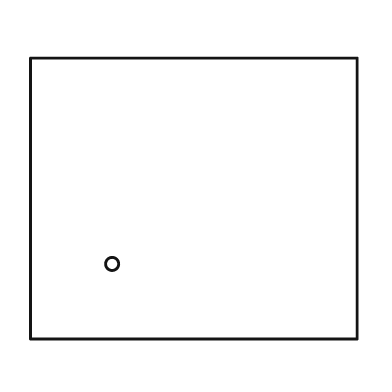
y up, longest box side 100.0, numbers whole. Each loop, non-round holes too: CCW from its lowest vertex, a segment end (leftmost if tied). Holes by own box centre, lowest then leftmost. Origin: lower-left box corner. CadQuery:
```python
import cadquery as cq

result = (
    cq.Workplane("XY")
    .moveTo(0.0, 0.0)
    .lineTo(100.0, 0.0)
    .lineTo(100.0, 86.0)
    .lineTo(0.0, 86.0)
    .close()
    .moveTo(25.0, 23.0)
    .circle(2.0)
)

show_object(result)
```